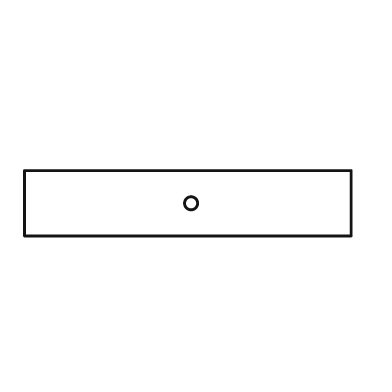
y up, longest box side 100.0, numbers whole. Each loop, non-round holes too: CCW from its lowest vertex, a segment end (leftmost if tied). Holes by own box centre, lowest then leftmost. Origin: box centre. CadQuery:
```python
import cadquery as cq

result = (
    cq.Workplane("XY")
    .moveTo(-50.0, -10.0)
    .lineTo(50.0, -10.0)
    .lineTo(50.0, 10.0)
    .lineTo(-50.0, 10.0)
    .close()
    .moveTo(1.0, 0.0)
    .circle(2.0)
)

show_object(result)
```